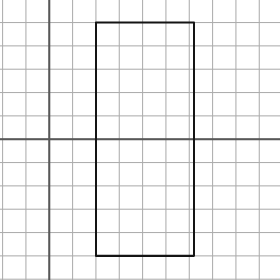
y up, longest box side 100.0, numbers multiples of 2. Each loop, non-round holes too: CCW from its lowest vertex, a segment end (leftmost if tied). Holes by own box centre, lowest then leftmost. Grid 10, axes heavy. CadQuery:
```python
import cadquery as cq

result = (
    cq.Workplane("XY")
    .moveTo(20.0, -50.0)
    .lineTo(62.0, -50.0)
    .lineTo(62.0, 50.0)
    .lineTo(20.0, 50.0)
    .close()
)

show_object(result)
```